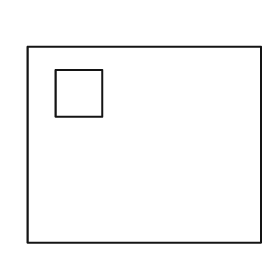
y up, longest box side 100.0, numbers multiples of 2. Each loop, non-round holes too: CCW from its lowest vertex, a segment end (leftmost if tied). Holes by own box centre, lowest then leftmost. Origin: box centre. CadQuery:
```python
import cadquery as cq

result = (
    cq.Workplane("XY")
    .moveTo(-50.0, -42.0)
    .lineTo(50.0, -42.0)
    .lineTo(50.0, 42.0)
    .lineTo(-50.0, 42.0)
    .close()
    .moveTo(-38.0, 12.0)
    .lineTo(-18.0, 12.0)
    .lineTo(-18.0, 32.0)
    .lineTo(-38.0, 32.0)
    .close()
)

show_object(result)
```